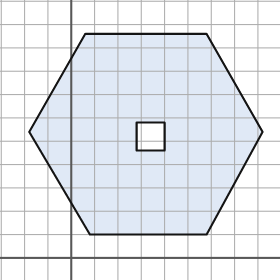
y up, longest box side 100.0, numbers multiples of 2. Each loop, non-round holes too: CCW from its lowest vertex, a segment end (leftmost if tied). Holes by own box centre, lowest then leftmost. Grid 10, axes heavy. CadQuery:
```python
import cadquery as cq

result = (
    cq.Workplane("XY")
    .moveTo(8.0, 10.0)
    .lineTo(58.0, 10.0)
    .lineTo(82.0, 54.0)
    .lineTo(58.0, 96.0)
    .lineTo(6.0, 96.0)
    .lineTo(-18.0, 54.0)
    .close()
    .moveTo(28.0, 46.0)
    .lineTo(40.0, 46.0)
    .lineTo(40.0, 58.0)
    .lineTo(28.0, 58.0)
    .close()
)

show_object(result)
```